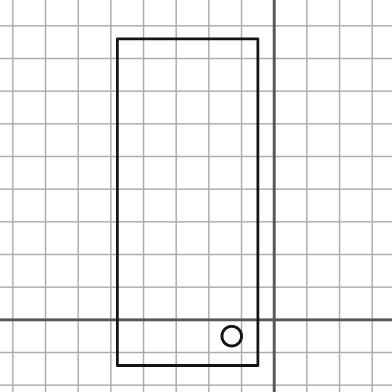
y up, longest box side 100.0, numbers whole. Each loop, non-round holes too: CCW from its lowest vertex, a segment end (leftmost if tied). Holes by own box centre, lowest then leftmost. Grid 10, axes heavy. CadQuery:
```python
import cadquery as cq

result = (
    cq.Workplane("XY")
    .moveTo(-48.0, -14.0)
    .lineTo(-5.0, -14.0)
    .lineTo(-5.0, 86.0)
    .lineTo(-48.0, 86.0)
    .close()
    .moveTo(-13.0, -5.0)
    .circle(3.0)
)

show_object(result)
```